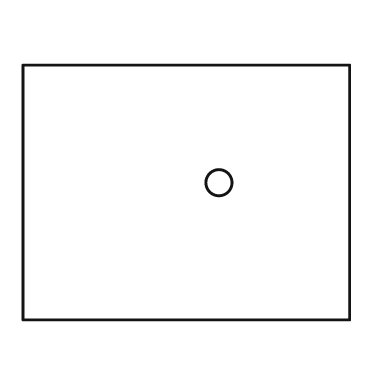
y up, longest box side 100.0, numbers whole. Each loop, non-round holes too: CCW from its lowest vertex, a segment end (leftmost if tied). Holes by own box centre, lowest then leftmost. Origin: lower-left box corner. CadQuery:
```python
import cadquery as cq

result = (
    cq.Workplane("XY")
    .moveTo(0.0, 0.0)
    .lineTo(100.0, 0.0)
    .lineTo(100.0, 78.0)
    .lineTo(0.0, 78.0)
    .close()
    .moveTo(60.0, 42.0)
    .circle(4.0)
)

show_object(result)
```